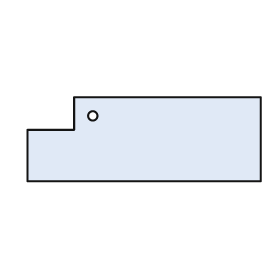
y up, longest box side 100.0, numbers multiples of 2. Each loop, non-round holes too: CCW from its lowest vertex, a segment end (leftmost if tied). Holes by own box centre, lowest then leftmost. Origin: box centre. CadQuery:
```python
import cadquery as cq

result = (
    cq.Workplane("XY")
    .moveTo(-50.0, -18.0)
    .lineTo(50.0, -18.0)
    .lineTo(50.0, 18.0)
    .lineTo(-30.0, 18.0)
    .lineTo(-30.0, 4.0)
    .lineTo(-50.0, 4.0)
    .close()
    .moveTo(-22.0, 10.0)
    .circle(2.0)
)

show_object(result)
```